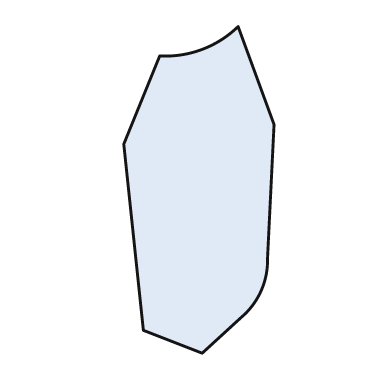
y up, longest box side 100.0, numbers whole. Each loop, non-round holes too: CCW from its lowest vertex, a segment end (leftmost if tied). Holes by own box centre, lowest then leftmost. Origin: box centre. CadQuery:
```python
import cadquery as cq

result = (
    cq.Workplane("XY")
    .moveTo(1.0, -50.0)
    .lineTo(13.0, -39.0)
    .threePointArc((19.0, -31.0), (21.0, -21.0))
    .lineTo(23.0, 20.0)
    .lineTo(12.0, 50.0)
    .threePointArc((1.0, 43.0), (-12.0, 41.0))
    .lineTo(-23.0, 14.0)
    .lineTo(-17.0, -43.0)
    .close()
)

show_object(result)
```